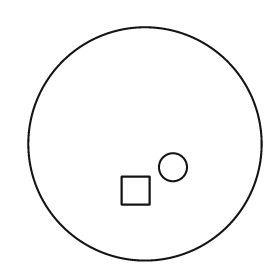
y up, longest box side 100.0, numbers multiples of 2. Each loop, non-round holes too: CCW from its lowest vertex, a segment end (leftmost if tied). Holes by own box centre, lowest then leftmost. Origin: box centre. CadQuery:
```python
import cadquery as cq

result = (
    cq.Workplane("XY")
    .moveTo(0.0, 0.0)
    .circle(50.0)
    .moveTo(-10.0, -26.0)
    .lineTo(2.0, -26.0)
    .lineTo(2.0, -14.0)
    .lineTo(-10.0, -14.0)
    .close()
    .moveTo(12.0, -10.0)
    .circle(6.0)
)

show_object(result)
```